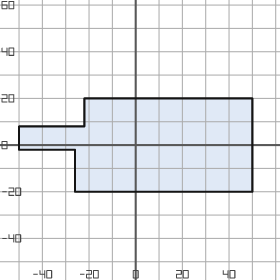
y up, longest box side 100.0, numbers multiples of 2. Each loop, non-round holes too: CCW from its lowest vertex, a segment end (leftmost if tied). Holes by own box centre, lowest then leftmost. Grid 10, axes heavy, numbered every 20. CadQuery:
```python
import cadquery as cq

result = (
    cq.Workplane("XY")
    .moveTo(-26.0, -20.0)
    .lineTo(50.0, -20.0)
    .lineTo(50.0, 20.0)
    .lineTo(-22.0, 20.0)
    .lineTo(-22.0, 8.0)
    .lineTo(-50.0, 8.0)
    .lineTo(-50.0, -2.0)
    .lineTo(-26.0, -2.0)
    .close()
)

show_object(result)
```